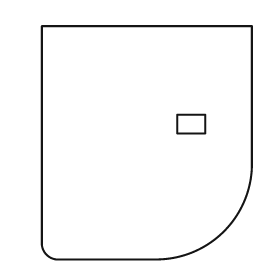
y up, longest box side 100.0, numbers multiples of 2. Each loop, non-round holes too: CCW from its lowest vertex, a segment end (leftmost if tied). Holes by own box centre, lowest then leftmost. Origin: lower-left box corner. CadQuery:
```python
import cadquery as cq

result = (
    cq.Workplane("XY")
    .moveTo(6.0, 0.0)
    .lineTo(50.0, 0.0)
    .threePointArc((78.0, 12.0), (90.0, 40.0))
    .lineTo(90.0, 100.0)
    .lineTo(0.0, 100.0)
    .lineTo(0.0, 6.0)
    .threePointArc((2.0, 2.0), (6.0, 0.0))
    .close()
    .moveTo(58.0, 54.0)
    .lineTo(70.0, 54.0)
    .lineTo(70.0, 62.0)
    .lineTo(58.0, 62.0)
    .close()
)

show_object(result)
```